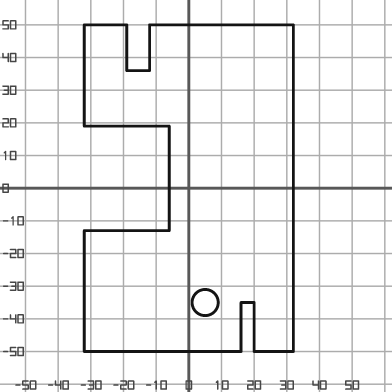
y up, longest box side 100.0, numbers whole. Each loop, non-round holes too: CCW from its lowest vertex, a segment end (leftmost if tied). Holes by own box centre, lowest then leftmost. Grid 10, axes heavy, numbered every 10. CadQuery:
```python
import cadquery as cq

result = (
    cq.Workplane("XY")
    .moveTo(-32.0, -50.0)
    .lineTo(16.0, -50.0)
    .lineTo(16.0, -35.0)
    .lineTo(20.0, -35.0)
    .lineTo(20.0, -50.0)
    .lineTo(32.0, -50.0)
    .lineTo(32.0, 50.0)
    .lineTo(-12.0, 50.0)
    .lineTo(-12.0, 36.0)
    .lineTo(-19.0, 36.0)
    .lineTo(-19.0, 50.0)
    .lineTo(-32.0, 50.0)
    .lineTo(-32.0, 19.0)
    .lineTo(-6.0, 19.0)
    .lineTo(-6.0, -13.0)
    .lineTo(-32.0, -13.0)
    .close()
    .moveTo(5.0, -35.0)
    .circle(4.0)
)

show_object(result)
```